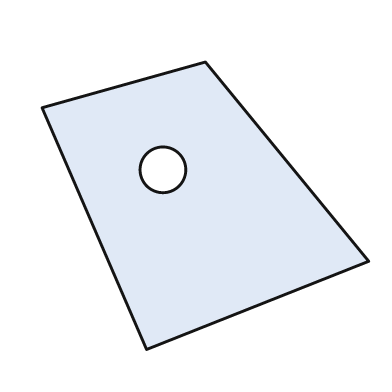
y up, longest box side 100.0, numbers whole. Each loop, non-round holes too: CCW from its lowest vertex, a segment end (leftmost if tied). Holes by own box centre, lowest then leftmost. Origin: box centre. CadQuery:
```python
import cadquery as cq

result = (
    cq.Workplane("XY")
    .moveTo(-18.0, -44.0)
    .lineTo(50.0, -17.0)
    .lineTo(0.0, 44.0)
    .lineTo(-50.0, 30.0)
    .close()
    .moveTo(-13.0, 11.0)
    .circle(7.0)
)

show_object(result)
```